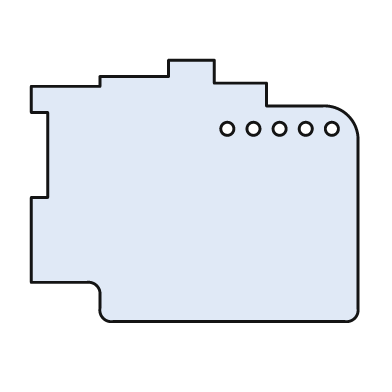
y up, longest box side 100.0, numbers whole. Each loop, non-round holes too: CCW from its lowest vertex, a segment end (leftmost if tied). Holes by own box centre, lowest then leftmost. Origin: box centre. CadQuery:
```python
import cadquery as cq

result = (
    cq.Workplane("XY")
    .moveTo(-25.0, -40.0)
    .lineTo(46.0, -40.0)
    .threePointArc((49.0, -39.0), (50.0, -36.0))
    .lineTo(50.0, 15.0)
    .threePointArc((47.0, 23.0), (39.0, 26.0))
    .lineTo(22.0, 26.0)
    .lineTo(22.0, 33.0)
    .lineTo(6.0, 33.0)
    .lineTo(6.0, 40.0)
    .lineTo(-8.0, 40.0)
    .lineTo(-8.0, 35.0)
    .lineTo(-29.0, 35.0)
    .lineTo(-29.0, 32.0)
    .lineTo(-50.0, 32.0)
    .lineTo(-50.0, 24.0)
    .lineTo(-45.0, 24.0)
    .lineTo(-45.0, -2.0)
    .lineTo(-50.0, -2.0)
    .lineTo(-50.0, -28.0)
    .lineTo(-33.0, -28.0)
    .threePointArc((-30.0, -29.0), (-29.0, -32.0))
    .lineTo(-29.0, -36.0)
    .threePointArc((-28.0, -39.0), (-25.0, -40.0))
    .close()
    .moveTo(10.0, 19.0)
    .circle(2.0)
    .moveTo(18.0, 19.0)
    .circle(2.0)
    .moveTo(26.0, 19.0)
    .circle(2.0)
    .moveTo(34.0, 19.0)
    .circle(2.0)
    .moveTo(42.0, 19.0)
    .circle(2.0)
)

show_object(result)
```